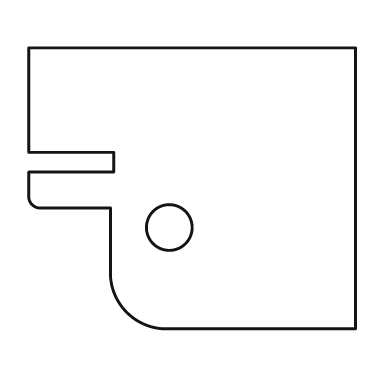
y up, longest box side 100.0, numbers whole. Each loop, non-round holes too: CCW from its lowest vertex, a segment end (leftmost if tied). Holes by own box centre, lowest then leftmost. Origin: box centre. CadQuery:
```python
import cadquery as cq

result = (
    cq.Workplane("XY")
    .moveTo(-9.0, -43.0)
    .lineTo(50.0, -43.0)
    .lineTo(50.0, 43.0)
    .lineTo(-50.0, 43.0)
    .lineTo(-50.0, 11.0)
    .lineTo(-24.0, 11.0)
    .lineTo(-24.0, 5.0)
    .lineTo(-50.0, 5.0)
    .lineTo(-50.0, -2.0)
    .threePointArc((-49.0, -5.0), (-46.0, -6.0))
    .lineTo(-25.0, -6.0)
    .lineTo(-25.0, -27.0)
    .threePointArc((-20.0, -38.0), (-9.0, -43.0))
    .close()
    .moveTo(-7.0, -12.0)
    .circle(7.0)
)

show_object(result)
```